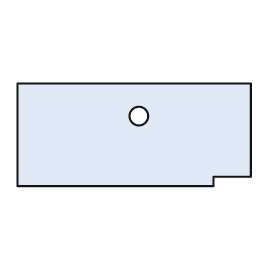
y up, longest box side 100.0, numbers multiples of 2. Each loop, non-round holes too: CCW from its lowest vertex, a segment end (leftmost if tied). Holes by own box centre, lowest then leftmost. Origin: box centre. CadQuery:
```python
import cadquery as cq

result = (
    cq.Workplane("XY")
    .moveTo(-50.0, -22.0)
    .lineTo(34.0, -22.0)
    .lineTo(34.0, -18.0)
    .lineTo(50.0, -18.0)
    .lineTo(50.0, 22.0)
    .lineTo(-50.0, 22.0)
    .close()
    .moveTo(2.0, 8.0)
    .circle(4.0)
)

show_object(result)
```